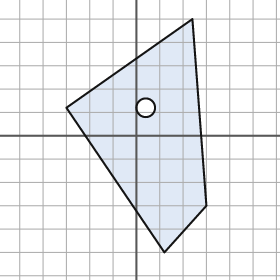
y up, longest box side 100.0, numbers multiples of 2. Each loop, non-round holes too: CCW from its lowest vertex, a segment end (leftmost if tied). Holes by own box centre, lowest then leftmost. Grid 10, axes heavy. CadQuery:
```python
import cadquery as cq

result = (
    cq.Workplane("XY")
    .moveTo(12.0, -50.0)
    .lineTo(30.0, -30.0)
    .lineTo(24.0, 50.0)
    .lineTo(-30.0, 12.0)
    .close()
    .moveTo(4.0, 12.0)
    .circle(4.0)
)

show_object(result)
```